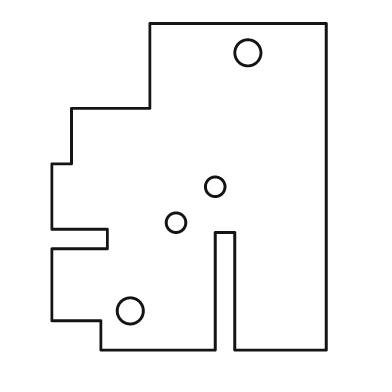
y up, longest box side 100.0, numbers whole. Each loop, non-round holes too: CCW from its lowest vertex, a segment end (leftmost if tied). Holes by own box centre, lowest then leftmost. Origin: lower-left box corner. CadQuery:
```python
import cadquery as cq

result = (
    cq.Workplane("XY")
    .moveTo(15.0, 0.0)
    .lineTo(50.0, 0.0)
    .lineTo(50.0, 36.0)
    .lineTo(56.0, 36.0)
    .lineTo(56.0, 0.0)
    .lineTo(84.0, 0.0)
    .lineTo(84.0, 100.0)
    .lineTo(30.0, 100.0)
    .lineTo(30.0, 74.0)
    .lineTo(6.0, 74.0)
    .lineTo(6.0, 57.0)
    .lineTo(0.0, 57.0)
    .lineTo(0.0, 37.0)
    .lineTo(17.0, 37.0)
    .lineTo(17.0, 31.0)
    .lineTo(0.0, 31.0)
    .lineTo(0.0, 9.0)
    .lineTo(15.0, 9.0)
    .close()
    .moveTo(24.0, 12.0)
    .circle(4.0)
    .moveTo(38.0, 39.0)
    .circle(3.0)
    .moveTo(50.0, 50.0)
    .circle(3.0)
    .moveTo(60.0, 91.0)
    .circle(4.0)
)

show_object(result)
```